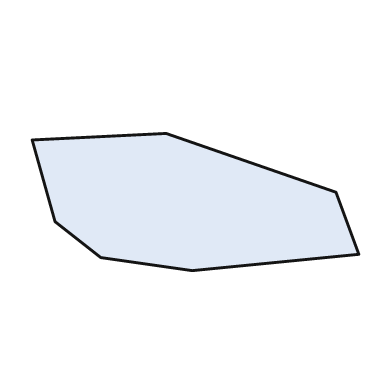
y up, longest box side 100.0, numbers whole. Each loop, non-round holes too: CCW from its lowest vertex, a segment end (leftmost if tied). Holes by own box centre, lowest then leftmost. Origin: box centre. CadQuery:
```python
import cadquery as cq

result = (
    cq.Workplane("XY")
    .moveTo(-1.0, -21.0)
    .lineTo(50.0, -16.0)
    .lineTo(43.0, 3.0)
    .lineTo(-9.0, 21.0)
    .lineTo(-50.0, 19.0)
    .lineTo(-43.0, -6.0)
    .lineTo(-29.0, -17.0)
    .close()
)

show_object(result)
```